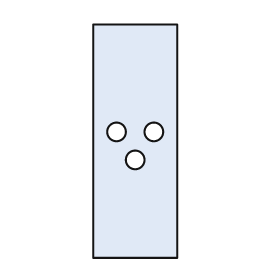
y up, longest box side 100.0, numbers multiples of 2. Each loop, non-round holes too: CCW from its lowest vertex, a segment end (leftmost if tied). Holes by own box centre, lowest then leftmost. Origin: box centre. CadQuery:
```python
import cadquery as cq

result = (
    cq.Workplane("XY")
    .moveTo(-18.0, -50.0)
    .lineTo(18.0, -50.0)
    .lineTo(18.0, 50.0)
    .lineTo(-18.0, 50.0)
    .close()
    .moveTo(0.0, -8.0)
    .circle(4.0)
    .moveTo(-8.0, 4.0)
    .circle(4.0)
    .moveTo(8.0, 4.0)
    .circle(4.0)
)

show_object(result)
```